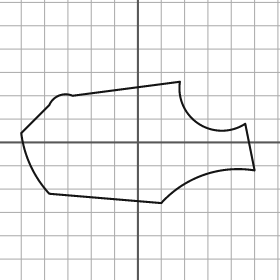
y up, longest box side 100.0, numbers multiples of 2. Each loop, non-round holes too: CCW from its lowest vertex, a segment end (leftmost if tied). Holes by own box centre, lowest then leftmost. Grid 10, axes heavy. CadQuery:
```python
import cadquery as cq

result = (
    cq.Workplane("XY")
    .moveTo(10.0, -26.0)
    .threePointArc((28.0, -14.0), (50.0, -12.0))
    .lineTo(46.0, 8.0)
    .threePointArc((26.0, 8.0), (18.0, 26.0))
    .lineTo(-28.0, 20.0)
    .threePointArc((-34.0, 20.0), (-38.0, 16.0))
    .lineTo(-50.0, 4.0)
    .threePointArc((-46.0, -10.0), (-38.0, -22.0))
    .close()
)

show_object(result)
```